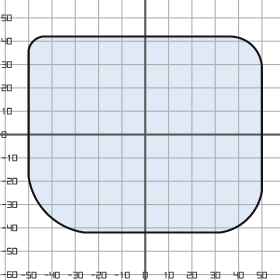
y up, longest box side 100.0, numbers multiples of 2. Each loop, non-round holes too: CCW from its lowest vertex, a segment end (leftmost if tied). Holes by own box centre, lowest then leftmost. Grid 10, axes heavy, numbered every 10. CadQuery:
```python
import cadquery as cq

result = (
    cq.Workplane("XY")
    .moveTo(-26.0, -42.0)
    .lineTo(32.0, -42.0)
    .threePointArc((44.0, -36.0), (50.0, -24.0))
    .lineTo(50.0, 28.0)
    .threePointArc((46.0, 38.0), (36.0, 42.0))
    .lineTo(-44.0, 42.0)
    .threePointArc((-48.0, 40.0), (-50.0, 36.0))
    .lineTo(-50.0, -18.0)
    .threePointArc((-42.0, -34.0), (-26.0, -42.0))
    .close()
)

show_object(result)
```